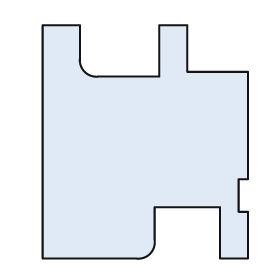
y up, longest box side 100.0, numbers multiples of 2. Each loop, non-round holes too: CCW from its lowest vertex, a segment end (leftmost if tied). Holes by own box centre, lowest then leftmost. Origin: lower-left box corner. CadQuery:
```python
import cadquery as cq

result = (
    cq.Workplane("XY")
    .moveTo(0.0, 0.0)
    .lineTo(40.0, 0.0)
    .threePointArc((46.0, 2.0), (48.0, 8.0))
    .lineTo(48.0, 22.0)
    .lineTo(76.0, 22.0)
    .lineTo(76.0, 0.0)
    .lineTo(88.0, 0.0)
    .lineTo(88.0, 20.0)
    .lineTo(84.0, 20.0)
    .lineTo(84.0, 34.0)
    .lineTo(88.0, 34.0)
    .lineTo(88.0, 80.0)
    .lineTo(62.0, 80.0)
    .lineTo(62.0, 100.0)
    .lineTo(50.0, 100.0)
    .lineTo(50.0, 78.0)
    .lineTo(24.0, 78.0)
    .threePointArc((18.0, 80.0), (16.0, 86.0))
    .lineTo(16.0, 100.0)
    .lineTo(0.0, 100.0)
    .close()
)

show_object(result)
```